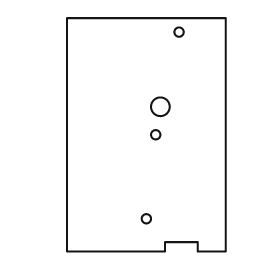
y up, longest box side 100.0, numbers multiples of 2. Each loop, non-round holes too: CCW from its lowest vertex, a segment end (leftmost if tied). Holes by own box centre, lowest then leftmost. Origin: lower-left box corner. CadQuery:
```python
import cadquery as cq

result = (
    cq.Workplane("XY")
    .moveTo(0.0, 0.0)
    .lineTo(42.0, 0.0)
    .lineTo(42.0, 4.0)
    .lineTo(56.0, 4.0)
    .lineTo(56.0, 0.0)
    .lineTo(68.0, 0.0)
    .lineTo(68.0, 100.0)
    .lineTo(0.0, 100.0)
    .close()
    .moveTo(34.0, 14.0)
    .circle(2.0)
    .moveTo(38.0, 50.0)
    .circle(2.0)
    .moveTo(40.0, 62.0)
    .circle(4.0)
    .moveTo(48.0, 94.0)
    .circle(2.0)
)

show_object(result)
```